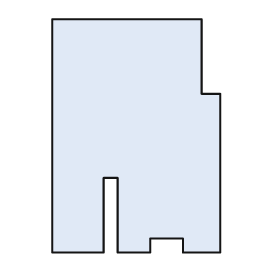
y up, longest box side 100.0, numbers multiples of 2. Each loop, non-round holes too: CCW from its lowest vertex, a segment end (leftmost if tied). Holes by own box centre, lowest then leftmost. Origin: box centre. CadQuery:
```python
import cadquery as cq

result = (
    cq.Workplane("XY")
    .moveTo(-36.0, -50.0)
    .lineTo(-14.0, -50.0)
    .lineTo(-14.0, -18.0)
    .lineTo(-8.0, -18.0)
    .lineTo(-8.0, -50.0)
    .lineTo(6.0, -50.0)
    .lineTo(6.0, -44.0)
    .lineTo(20.0, -44.0)
    .lineTo(20.0, -50.0)
    .lineTo(36.0, -50.0)
    .lineTo(36.0, 18.0)
    .lineTo(28.0, 18.0)
    .lineTo(28.0, 50.0)
    .lineTo(-36.0, 50.0)
    .close()
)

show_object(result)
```